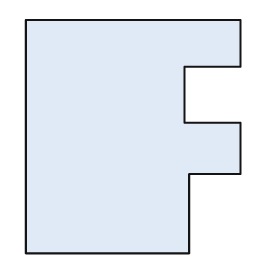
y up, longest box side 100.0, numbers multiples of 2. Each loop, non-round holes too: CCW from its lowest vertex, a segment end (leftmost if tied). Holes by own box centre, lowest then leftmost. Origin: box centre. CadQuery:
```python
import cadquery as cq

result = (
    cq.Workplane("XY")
    .moveTo(-46.0, -50.0)
    .lineTo(24.0, -50.0)
    .lineTo(24.0, -16.0)
    .lineTo(46.0, -16.0)
    .lineTo(46.0, 6.0)
    .lineTo(22.0, 6.0)
    .lineTo(22.0, 30.0)
    .lineTo(46.0, 30.0)
    .lineTo(46.0, 50.0)
    .lineTo(-46.0, 50.0)
    .close()
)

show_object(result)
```